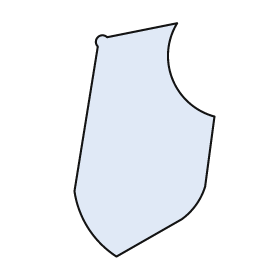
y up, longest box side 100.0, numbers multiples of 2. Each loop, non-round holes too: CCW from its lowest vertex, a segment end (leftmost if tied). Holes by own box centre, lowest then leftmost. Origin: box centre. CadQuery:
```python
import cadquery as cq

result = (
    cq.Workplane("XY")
    .moveTo(-12.0, -50.0)
    .lineTo(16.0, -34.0)
    .threePointArc((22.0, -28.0), (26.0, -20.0))
    .lineTo(30.0, 10.0)
    .threePointArc((12.0, 26.0), (14.0, 50.0))
    .lineTo(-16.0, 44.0)
    .threePointArc((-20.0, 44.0), (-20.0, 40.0))
    .lineTo(-30.0, -22.0)
    .threePointArc((-24.0, -38.0), (-12.0, -50.0))
    .close()
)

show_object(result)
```